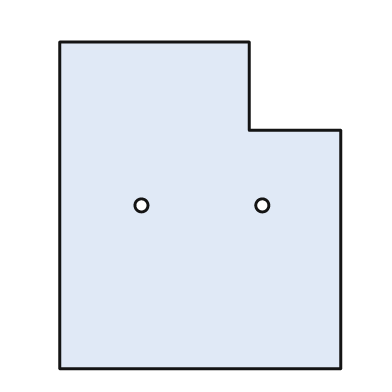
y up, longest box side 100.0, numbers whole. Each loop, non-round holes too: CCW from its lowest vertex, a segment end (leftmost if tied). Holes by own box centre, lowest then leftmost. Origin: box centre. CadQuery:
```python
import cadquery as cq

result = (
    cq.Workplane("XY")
    .moveTo(-43.0, -50.0)
    .lineTo(43.0, -50.0)
    .lineTo(43.0, 23.0)
    .lineTo(15.0, 23.0)
    .lineTo(15.0, 50.0)
    .lineTo(-43.0, 50.0)
    .close()
    .moveTo(-18.0, 0.0)
    .circle(2.0)
    .moveTo(19.0, 0.0)
    .circle(2.0)
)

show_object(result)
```